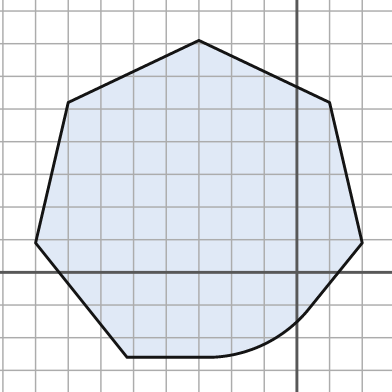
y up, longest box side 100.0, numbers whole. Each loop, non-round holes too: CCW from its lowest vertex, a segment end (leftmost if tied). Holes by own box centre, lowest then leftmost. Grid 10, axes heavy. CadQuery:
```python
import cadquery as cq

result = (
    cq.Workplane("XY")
    .moveTo(-52.0, -26.0)
    .lineTo(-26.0, -26.0)
    .threePointArc((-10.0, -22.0), (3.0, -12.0))
    .lineTo(20.0, 9.0)
    .lineTo(10.0, 52.0)
    .lineTo(-30.0, 71.0)
    .lineTo(-70.0, 52.0)
    .lineTo(-80.0, 9.0)
    .close()
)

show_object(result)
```